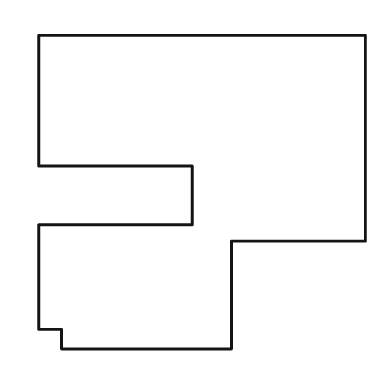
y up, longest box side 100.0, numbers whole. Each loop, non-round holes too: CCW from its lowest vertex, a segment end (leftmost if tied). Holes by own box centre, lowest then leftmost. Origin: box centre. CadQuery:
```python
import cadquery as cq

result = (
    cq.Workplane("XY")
    .moveTo(-43.0, -48.0)
    .lineTo(9.0, -48.0)
    .lineTo(9.0, -15.0)
    .lineTo(50.0, -15.0)
    .lineTo(50.0, 48.0)
    .lineTo(-50.0, 48.0)
    .lineTo(-50.0, 8.0)
    .lineTo(-3.0, 8.0)
    .lineTo(-3.0, -10.0)
    .lineTo(-50.0, -10.0)
    .lineTo(-50.0, -42.0)
    .lineTo(-43.0, -42.0)
    .close()
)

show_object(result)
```